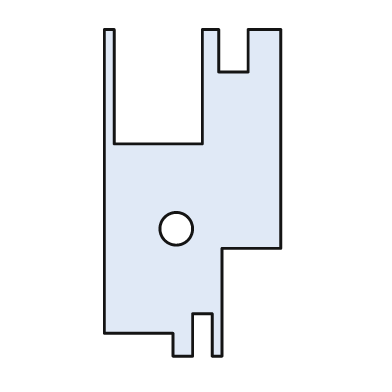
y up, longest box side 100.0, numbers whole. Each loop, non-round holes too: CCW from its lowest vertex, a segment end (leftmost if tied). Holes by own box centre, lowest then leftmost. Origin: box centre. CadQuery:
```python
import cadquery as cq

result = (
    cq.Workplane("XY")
    .moveTo(-6.0, -50.0)
    .lineTo(0.0, -50.0)
    .lineTo(0.0, -37.0)
    .lineTo(6.0, -37.0)
    .lineTo(6.0, -50.0)
    .lineTo(9.0, -50.0)
    .lineTo(9.0, -17.0)
    .lineTo(27.0, -17.0)
    .lineTo(27.0, 50.0)
    .lineTo(17.0, 50.0)
    .lineTo(17.0, 37.0)
    .lineTo(8.0, 37.0)
    .lineTo(8.0, 50.0)
    .lineTo(3.0, 50.0)
    .lineTo(3.0, 15.0)
    .lineTo(-24.0, 15.0)
    .lineTo(-24.0, 50.0)
    .lineTo(-27.0, 50.0)
    .lineTo(-27.0, -43.0)
    .lineTo(-6.0, -43.0)
    .close()
    .moveTo(-5.0, -11.0)
    .circle(5.0)
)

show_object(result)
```